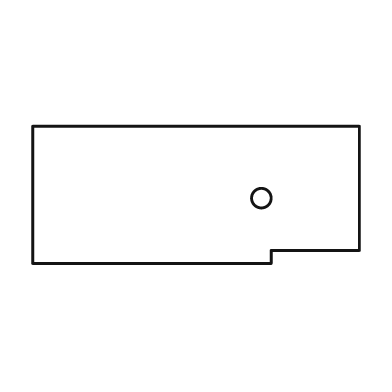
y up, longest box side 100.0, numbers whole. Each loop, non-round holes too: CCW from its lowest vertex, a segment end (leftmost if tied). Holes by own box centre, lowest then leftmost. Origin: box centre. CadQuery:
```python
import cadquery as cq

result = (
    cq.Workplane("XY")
    .moveTo(-50.0, -21.0)
    .lineTo(23.0, -21.0)
    .lineTo(23.0, -17.0)
    .lineTo(50.0, -17.0)
    .lineTo(50.0, 21.0)
    .lineTo(-50.0, 21.0)
    .close()
    .moveTo(20.0, -1.0)
    .circle(3.0)
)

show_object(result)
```